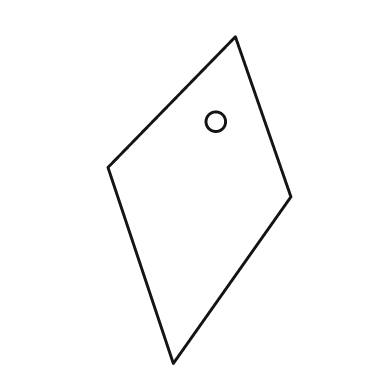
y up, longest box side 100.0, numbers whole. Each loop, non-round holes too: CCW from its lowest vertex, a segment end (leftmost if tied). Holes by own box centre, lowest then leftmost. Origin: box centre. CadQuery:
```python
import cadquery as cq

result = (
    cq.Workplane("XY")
    .moveTo(-8.0, -50.0)
    .lineTo(28.0, 1.0)
    .lineTo(11.0, 50.0)
    .lineTo(-28.0, 10.0)
    .close()
    .moveTo(5.0, 24.0)
    .circle(3.0)
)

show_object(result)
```